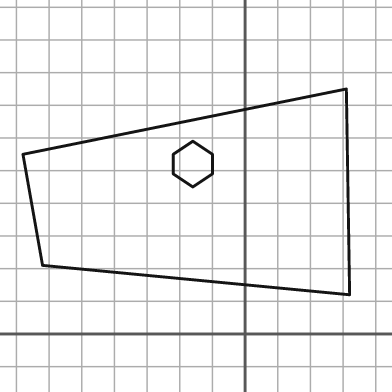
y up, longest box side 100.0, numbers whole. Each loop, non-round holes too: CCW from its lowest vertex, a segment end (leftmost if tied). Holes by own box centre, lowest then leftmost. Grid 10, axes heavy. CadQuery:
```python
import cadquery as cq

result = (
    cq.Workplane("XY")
    .moveTo(32.0, 12.0)
    .lineTo(31.0, 75.0)
    .lineTo(-68.0, 55.0)
    .lineTo(-62.0, 21.0)
    .close()
    .moveTo(-16.0, 45.0)
    .lineTo(-10.0, 49.0)
    .lineTo(-10.0, 55.0)
    .lineTo(-16.0, 59.0)
    .lineTo(-22.0, 55.0)
    .lineTo(-22.0, 49.0)
    .close()
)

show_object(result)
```